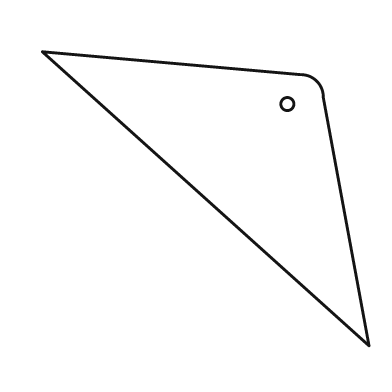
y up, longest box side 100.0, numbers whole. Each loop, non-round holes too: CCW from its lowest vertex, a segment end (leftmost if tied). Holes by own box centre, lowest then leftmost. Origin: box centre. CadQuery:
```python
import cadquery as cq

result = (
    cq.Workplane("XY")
    .moveTo(50.0, -45.0)
    .lineTo(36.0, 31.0)
    .threePointArc((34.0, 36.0), (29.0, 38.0))
    .lineTo(-50.0, 45.0)
    .close()
    .moveTo(25.0, 29.0)
    .circle(2.0)
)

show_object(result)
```